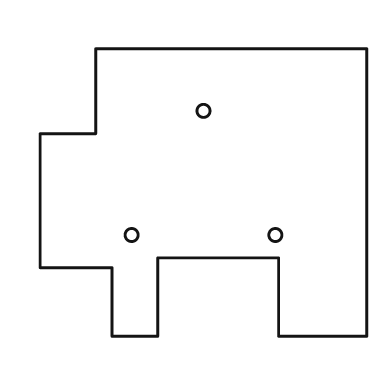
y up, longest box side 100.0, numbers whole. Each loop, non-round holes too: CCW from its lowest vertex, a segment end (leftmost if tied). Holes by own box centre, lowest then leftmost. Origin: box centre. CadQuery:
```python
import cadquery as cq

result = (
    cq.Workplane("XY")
    .moveTo(-28.0, -44.0)
    .lineTo(-14.0, -44.0)
    .lineTo(-14.0, -20.0)
    .lineTo(23.0, -20.0)
    .lineTo(23.0, -44.0)
    .lineTo(50.0, -44.0)
    .lineTo(50.0, 44.0)
    .lineTo(-33.0, 44.0)
    .lineTo(-33.0, 18.0)
    .lineTo(-50.0, 18.0)
    .lineTo(-50.0, -23.0)
    .lineTo(-28.0, -23.0)
    .close()
    .moveTo(-22.0, -13.0)
    .circle(2.0)
    .moveTo(22.0, -13.0)
    .circle(2.0)
    .moveTo(0.0, 25.0)
    .circle(2.0)
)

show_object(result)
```